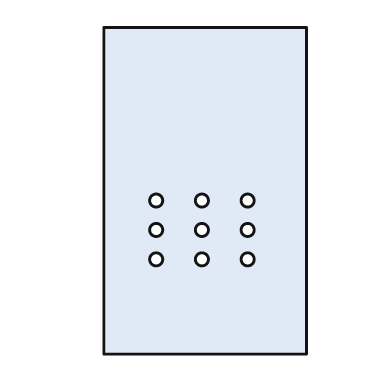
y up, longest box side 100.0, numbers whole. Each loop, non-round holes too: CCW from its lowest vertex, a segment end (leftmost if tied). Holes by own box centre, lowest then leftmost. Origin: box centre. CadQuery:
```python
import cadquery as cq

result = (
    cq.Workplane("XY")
    .moveTo(-31.0, -50.0)
    .lineTo(31.0, -50.0)
    .lineTo(31.0, 50.0)
    .lineTo(-31.0, 50.0)
    .close()
    .moveTo(-15.0, -21.0)
    .circle(2.0)
    .moveTo(-1.0, -21.0)
    .circle(2.0)
    .moveTo(13.0, -21.0)
    .circle(2.0)
    .moveTo(-15.0, -12.0)
    .circle(2.0)
    .moveTo(-1.0, -12.0)
    .circle(2.0)
    .moveTo(13.0, -12.0)
    .circle(2.0)
    .moveTo(-15.0, -3.0)
    .circle(2.0)
    .moveTo(-1.0, -3.0)
    .circle(2.0)
    .moveTo(13.0, -3.0)
    .circle(2.0)
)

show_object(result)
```